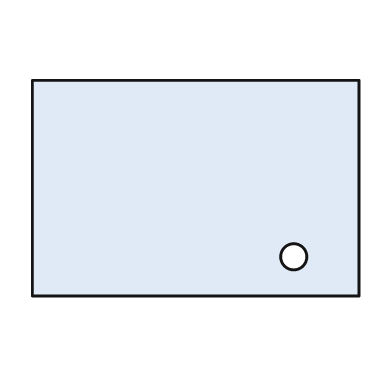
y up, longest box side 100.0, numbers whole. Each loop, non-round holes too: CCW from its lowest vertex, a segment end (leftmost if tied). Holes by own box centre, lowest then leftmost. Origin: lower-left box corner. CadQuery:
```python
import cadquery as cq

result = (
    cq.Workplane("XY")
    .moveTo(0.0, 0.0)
    .lineTo(100.0, 0.0)
    .lineTo(100.0, 66.0)
    .lineTo(0.0, 66.0)
    .close()
    .moveTo(80.0, 12.0)
    .circle(4.0)
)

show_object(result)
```